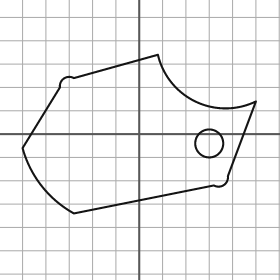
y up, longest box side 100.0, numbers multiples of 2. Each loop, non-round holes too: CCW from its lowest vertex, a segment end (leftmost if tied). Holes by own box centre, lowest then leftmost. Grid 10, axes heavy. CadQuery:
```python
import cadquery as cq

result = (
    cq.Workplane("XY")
    .moveTo(-28.0, -34.0)
    .lineTo(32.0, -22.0)
    .threePointArc((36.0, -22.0), (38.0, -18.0))
    .lineTo(50.0, 14.0)
    .threePointArc((24.0, 14.0), (8.0, 34.0))
    .lineTo(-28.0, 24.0)
    .threePointArc((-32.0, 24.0), (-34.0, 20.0))
    .lineTo(-50.0, -6.0)
    .threePointArc((-42.0, -22.0), (-28.0, -34.0))
    .close()
    .moveTo(30.0, -4.0)
    .circle(6.0)
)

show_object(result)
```